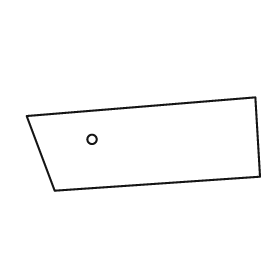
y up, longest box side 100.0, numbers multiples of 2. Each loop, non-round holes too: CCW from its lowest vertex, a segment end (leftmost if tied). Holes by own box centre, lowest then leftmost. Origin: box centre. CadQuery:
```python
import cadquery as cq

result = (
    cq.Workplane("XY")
    .moveTo(-38.0, -20.0)
    .lineTo(50.0, -14.0)
    .lineTo(48.0, 20.0)
    .lineTo(-50.0, 12.0)
    .close()
    .moveTo(-22.0, 2.0)
    .circle(2.0)
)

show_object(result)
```